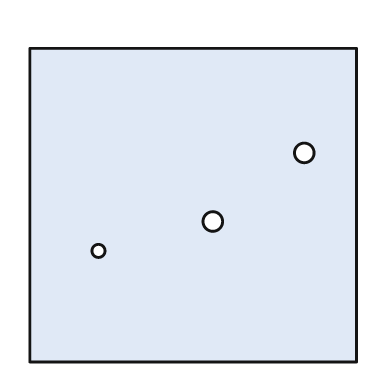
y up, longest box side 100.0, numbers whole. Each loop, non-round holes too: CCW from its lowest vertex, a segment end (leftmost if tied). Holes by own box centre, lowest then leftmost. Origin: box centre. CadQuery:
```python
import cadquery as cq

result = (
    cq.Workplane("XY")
    .moveTo(-50.0, -48.0)
    .lineTo(50.0, -48.0)
    .lineTo(50.0, 48.0)
    .lineTo(-50.0, 48.0)
    .close()
    .moveTo(-29.0, -14.0)
    .circle(2.0)
    .moveTo(6.0, -5.0)
    .circle(3.0)
    .moveTo(34.0, 16.0)
    .circle(3.0)
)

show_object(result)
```